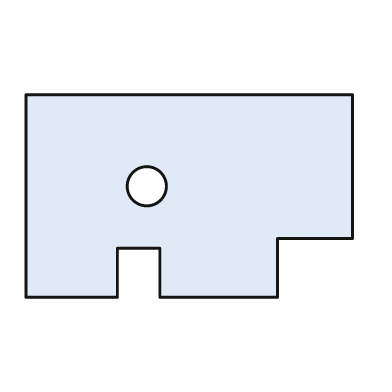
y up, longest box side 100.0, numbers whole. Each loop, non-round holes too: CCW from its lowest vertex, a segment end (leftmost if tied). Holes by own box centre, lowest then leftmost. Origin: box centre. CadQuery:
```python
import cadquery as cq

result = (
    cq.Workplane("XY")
    .moveTo(-50.0, -31.0)
    .lineTo(-22.0, -31.0)
    .lineTo(-22.0, -16.0)
    .lineTo(-9.0, -16.0)
    .lineTo(-9.0, -31.0)
    .lineTo(27.0, -31.0)
    .lineTo(27.0, -13.0)
    .lineTo(50.0, -13.0)
    .lineTo(50.0, 31.0)
    .lineTo(-50.0, 31.0)
    .close()
    .moveTo(-13.0, 3.0)
    .circle(6.0)
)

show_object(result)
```